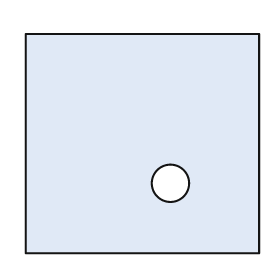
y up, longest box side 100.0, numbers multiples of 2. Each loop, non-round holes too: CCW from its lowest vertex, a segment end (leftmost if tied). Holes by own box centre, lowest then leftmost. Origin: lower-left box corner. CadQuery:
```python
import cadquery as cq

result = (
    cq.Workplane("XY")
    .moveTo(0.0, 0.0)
    .lineTo(100.0, 0.0)
    .lineTo(100.0, 94.0)
    .lineTo(0.0, 94.0)
    .close()
    .moveTo(62.0, 30.0)
    .circle(8.0)
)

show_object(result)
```